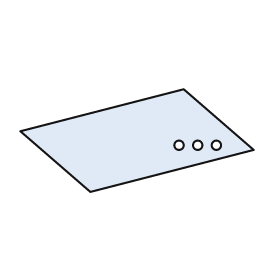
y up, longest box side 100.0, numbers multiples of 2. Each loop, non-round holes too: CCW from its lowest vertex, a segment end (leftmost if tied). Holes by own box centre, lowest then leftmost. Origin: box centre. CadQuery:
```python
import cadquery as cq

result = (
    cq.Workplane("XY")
    .moveTo(-20.0, -22.0)
    .lineTo(50.0, -4.0)
    .lineTo(20.0, 22.0)
    .lineTo(-50.0, 4.0)
    .close()
    .moveTo(18.0, -2.0)
    .circle(2.0)
    .moveTo(26.0, -2.0)
    .circle(2.0)
    .moveTo(34.0, -2.0)
    .circle(2.0)
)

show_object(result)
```